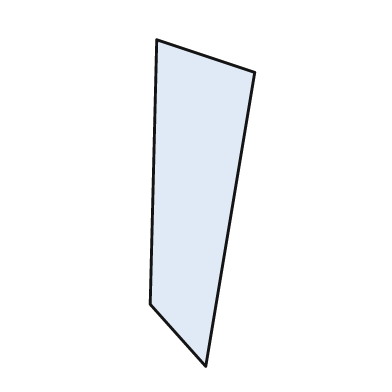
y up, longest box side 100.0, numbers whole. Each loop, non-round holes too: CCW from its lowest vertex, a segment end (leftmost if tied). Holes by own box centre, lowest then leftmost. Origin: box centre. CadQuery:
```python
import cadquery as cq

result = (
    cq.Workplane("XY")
    .moveTo(1.0, -50.0)
    .lineTo(16.0, 40.0)
    .lineTo(-14.0, 50.0)
    .lineTo(-16.0, -31.0)
    .close()
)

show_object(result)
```